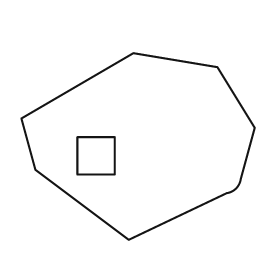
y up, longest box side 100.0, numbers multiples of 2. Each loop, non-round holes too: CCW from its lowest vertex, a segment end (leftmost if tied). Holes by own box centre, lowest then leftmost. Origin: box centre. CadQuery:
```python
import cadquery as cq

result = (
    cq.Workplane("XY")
    .moveTo(-4.0, -40.0)
    .lineTo(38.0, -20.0)
    .threePointArc((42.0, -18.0), (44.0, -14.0))
    .lineTo(50.0, 8.0)
    .lineTo(34.0, 34.0)
    .lineTo(-2.0, 40.0)
    .lineTo(-50.0, 12.0)
    .lineTo(-44.0, -10.0)
    .close()
    .moveTo(-26.0, -12.0)
    .lineTo(-10.0, -12.0)
    .lineTo(-10.0, 4.0)
    .lineTo(-26.0, 4.0)
    .close()
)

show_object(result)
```